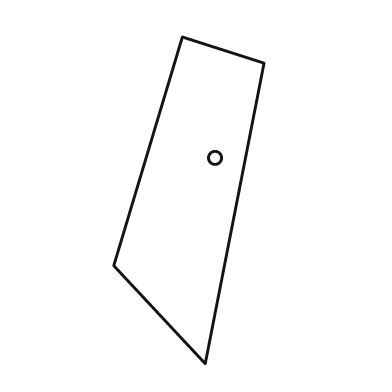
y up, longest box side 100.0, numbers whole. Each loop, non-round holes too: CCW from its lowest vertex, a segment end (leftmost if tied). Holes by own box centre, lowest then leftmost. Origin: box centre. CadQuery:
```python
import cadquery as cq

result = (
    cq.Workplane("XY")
    .moveTo(5.0, -50.0)
    .lineTo(23.0, 42.0)
    .lineTo(-2.0, 50.0)
    .lineTo(-23.0, -20.0)
    .close()
    .moveTo(8.0, 13.0)
    .circle(2.0)
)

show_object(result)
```